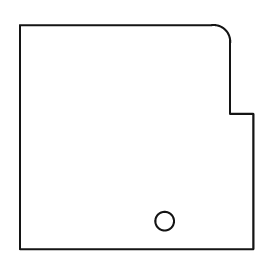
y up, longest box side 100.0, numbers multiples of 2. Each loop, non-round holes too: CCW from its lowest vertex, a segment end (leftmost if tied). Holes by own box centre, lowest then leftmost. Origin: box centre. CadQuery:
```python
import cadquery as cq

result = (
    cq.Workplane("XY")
    .moveTo(-50.0, -48.0)
    .lineTo(50.0, -48.0)
    .lineTo(50.0, 10.0)
    .lineTo(40.0, 10.0)
    .lineTo(40.0, 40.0)
    .threePointArc((38.0, 46.0), (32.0, 48.0))
    .lineTo(-50.0, 48.0)
    .close()
    .moveTo(12.0, -36.0)
    .circle(4.0)
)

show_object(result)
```